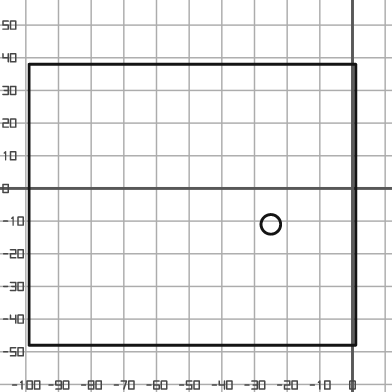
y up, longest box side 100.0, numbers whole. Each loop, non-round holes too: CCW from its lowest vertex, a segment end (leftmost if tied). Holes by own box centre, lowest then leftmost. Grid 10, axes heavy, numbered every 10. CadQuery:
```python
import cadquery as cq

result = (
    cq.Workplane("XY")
    .moveTo(-99.0, -48.0)
    .lineTo(1.0, -48.0)
    .lineTo(1.0, 38.0)
    .lineTo(-99.0, 38.0)
    .close()
    .moveTo(-25.0, -11.0)
    .circle(3.0)
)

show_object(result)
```